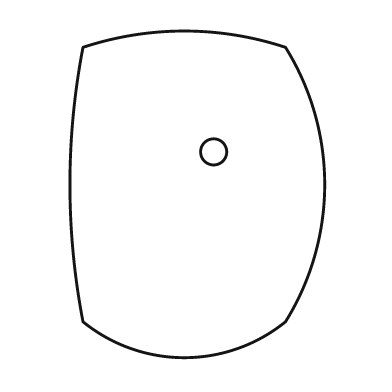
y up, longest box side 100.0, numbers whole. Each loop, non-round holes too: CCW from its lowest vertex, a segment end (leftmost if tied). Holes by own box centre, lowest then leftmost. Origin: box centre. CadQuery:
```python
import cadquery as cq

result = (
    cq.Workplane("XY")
    .moveTo(-35.0, -39.0)
    .threePointArc((-4.0, -50.0), (27.0, -39.0))
    .threePointArc((39.0, 3.0), (27.0, 45.0))
    .threePointArc((-4.0, 50.0), (-35.0, 45.0))
    .threePointArc((-39.0, 3.0), (-35.0, -39.0))
    .close()
    .moveTo(5.0, 13.0)
    .circle(4.0)
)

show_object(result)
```